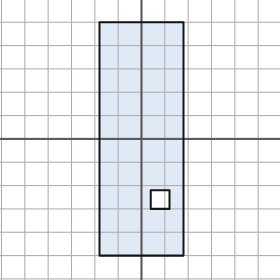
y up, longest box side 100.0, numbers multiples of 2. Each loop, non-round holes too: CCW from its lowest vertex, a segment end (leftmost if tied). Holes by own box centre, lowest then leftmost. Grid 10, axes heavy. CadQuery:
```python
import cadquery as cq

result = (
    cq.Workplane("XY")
    .moveTo(-18.0, -50.0)
    .lineTo(18.0, -50.0)
    .lineTo(18.0, 50.0)
    .lineTo(-18.0, 50.0)
    .close()
    .moveTo(4.0, -30.0)
    .lineTo(12.0, -30.0)
    .lineTo(12.0, -22.0)
    .lineTo(4.0, -22.0)
    .close()
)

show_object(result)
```